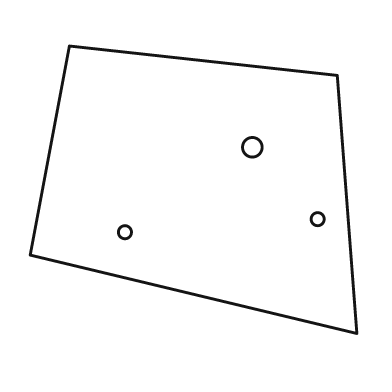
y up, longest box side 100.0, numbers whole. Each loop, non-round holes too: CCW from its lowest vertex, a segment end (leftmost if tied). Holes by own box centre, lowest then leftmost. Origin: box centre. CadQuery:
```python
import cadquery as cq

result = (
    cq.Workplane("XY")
    .moveTo(50.0, -44.0)
    .lineTo(44.0, 35.0)
    .lineTo(-38.0, 44.0)
    .lineTo(-50.0, -20.0)
    .close()
    .moveTo(-21.0, -13.0)
    .circle(2.0)
    .moveTo(38.0, -9.0)
    .circle(2.0)
    .moveTo(18.0, 13.0)
    .circle(3.0)
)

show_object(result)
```